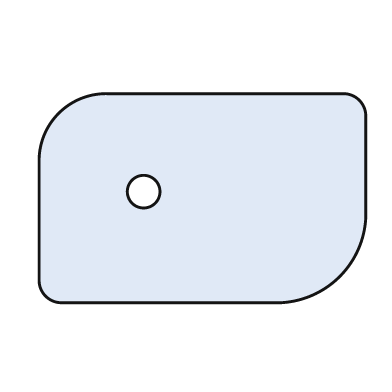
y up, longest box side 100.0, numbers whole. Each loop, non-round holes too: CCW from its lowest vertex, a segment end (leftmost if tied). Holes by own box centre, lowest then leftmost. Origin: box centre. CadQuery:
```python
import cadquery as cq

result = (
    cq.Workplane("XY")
    .moveTo(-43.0, -32.0)
    .lineTo(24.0, -32.0)
    .threePointArc((42.0, -24.0), (50.0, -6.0))
    .lineTo(50.0, 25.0)
    .threePointArc((48.0, 30.0), (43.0, 32.0))
    .lineTo(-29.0, 32.0)
    .threePointArc((-44.0, 26.0), (-50.0, 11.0))
    .lineTo(-50.0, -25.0)
    .threePointArc((-48.0, -30.0), (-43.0, -32.0))
    .close()
    .moveTo(-18.0, 2.0)
    .circle(5.0)
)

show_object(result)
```